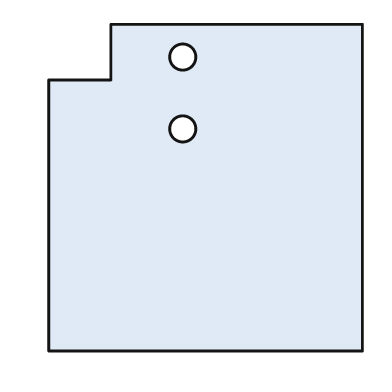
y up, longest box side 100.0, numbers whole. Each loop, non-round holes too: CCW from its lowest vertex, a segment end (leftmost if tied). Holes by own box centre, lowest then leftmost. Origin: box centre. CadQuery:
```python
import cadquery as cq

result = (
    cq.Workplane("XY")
    .moveTo(-48.0, -50.0)
    .lineTo(48.0, -50.0)
    .lineTo(48.0, 50.0)
    .lineTo(-29.0, 50.0)
    .lineTo(-29.0, 33.0)
    .lineTo(-48.0, 33.0)
    .close()
    .moveTo(-7.0, 18.0)
    .circle(4.0)
    .moveTo(-7.0, 40.0)
    .circle(4.0)
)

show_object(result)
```